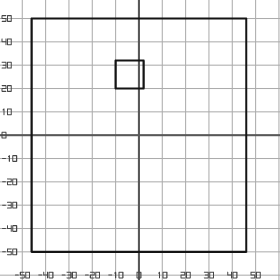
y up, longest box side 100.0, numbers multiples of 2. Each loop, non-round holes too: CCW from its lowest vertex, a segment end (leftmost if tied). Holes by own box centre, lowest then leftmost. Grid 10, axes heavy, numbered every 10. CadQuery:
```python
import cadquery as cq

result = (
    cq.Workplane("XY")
    .moveTo(-46.0, -50.0)
    .lineTo(46.0, -50.0)
    .lineTo(46.0, 50.0)
    .lineTo(-46.0, 50.0)
    .close()
    .moveTo(-10.0, 20.0)
    .lineTo(2.0, 20.0)
    .lineTo(2.0, 32.0)
    .lineTo(-10.0, 32.0)
    .close()
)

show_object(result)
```